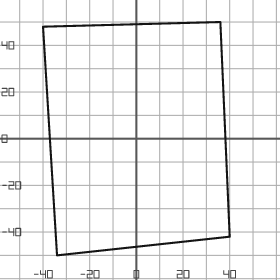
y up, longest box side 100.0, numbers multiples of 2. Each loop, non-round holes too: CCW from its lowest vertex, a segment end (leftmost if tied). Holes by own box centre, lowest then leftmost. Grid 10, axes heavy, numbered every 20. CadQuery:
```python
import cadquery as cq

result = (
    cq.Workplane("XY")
    .moveTo(-34.0, -50.0)
    .lineTo(40.0, -42.0)
    .lineTo(36.0, 50.0)
    .lineTo(-40.0, 48.0)
    .close()
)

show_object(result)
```